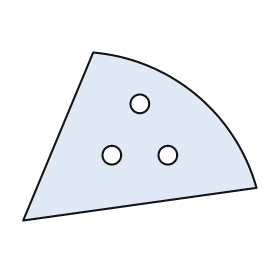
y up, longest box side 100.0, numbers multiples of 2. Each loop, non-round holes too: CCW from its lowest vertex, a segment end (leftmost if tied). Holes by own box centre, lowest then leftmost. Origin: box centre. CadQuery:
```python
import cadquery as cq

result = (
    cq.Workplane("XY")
    .moveTo(-50.0, -36.0)
    .lineTo(50.0, -22.0)
    .threePointArc((24.0, 18.0), (-20.0, 36.0))
    .close()
    .moveTo(-12.0, -8.0)
    .circle(4.0)
    .moveTo(12.0, -8.0)
    .circle(4.0)
    .moveTo(0.0, 14.0)
    .circle(4.0)
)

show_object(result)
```